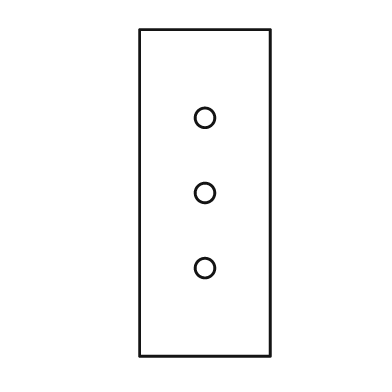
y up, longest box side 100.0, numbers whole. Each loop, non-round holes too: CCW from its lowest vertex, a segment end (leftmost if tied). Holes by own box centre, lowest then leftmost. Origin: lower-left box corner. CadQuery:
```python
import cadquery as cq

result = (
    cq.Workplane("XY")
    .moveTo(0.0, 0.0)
    .lineTo(40.0, 0.0)
    .lineTo(40.0, 100.0)
    .lineTo(0.0, 100.0)
    .close()
    .moveTo(20.0, 27.0)
    .circle(3.0)
    .moveTo(20.0, 50.0)
    .circle(3.0)
    .moveTo(20.0, 73.0)
    .circle(3.0)
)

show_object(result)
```